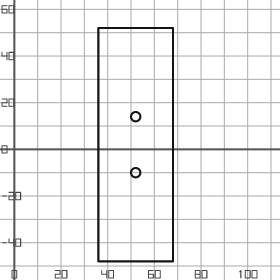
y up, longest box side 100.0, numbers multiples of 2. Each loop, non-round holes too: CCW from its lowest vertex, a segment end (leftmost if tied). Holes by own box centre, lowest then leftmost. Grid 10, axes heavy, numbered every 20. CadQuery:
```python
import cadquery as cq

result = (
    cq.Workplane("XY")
    .moveTo(36.0, -48.0)
    .lineTo(68.0, -48.0)
    .lineTo(68.0, 52.0)
    .lineTo(36.0, 52.0)
    .close()
    .moveTo(52.0, -10.0)
    .circle(2.0)
    .moveTo(52.0, 14.0)
    .circle(2.0)
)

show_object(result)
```